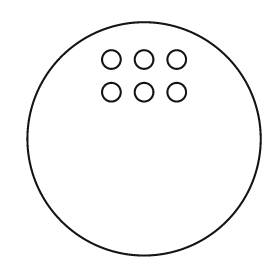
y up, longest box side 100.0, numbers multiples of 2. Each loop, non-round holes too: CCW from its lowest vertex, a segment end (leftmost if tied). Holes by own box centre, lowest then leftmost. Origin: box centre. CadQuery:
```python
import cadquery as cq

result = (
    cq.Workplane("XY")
    .moveTo(0.0, 0.0)
    .circle(50.0)
    .moveTo(-14.0, 20.0)
    .circle(4.0)
    .moveTo(0.0, 20.0)
    .circle(4.0)
    .moveTo(14.0, 20.0)
    .circle(4.0)
    .moveTo(-14.0, 34.0)
    .circle(4.0)
    .moveTo(0.0, 34.0)
    .circle(4.0)
    .moveTo(14.0, 34.0)
    .circle(4.0)
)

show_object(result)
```